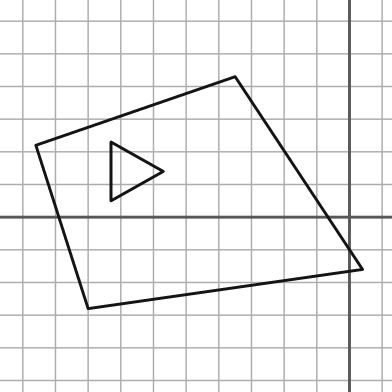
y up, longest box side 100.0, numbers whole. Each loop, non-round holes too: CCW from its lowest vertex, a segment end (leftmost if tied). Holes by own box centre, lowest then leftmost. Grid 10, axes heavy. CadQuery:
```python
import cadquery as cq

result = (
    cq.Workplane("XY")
    .moveTo(-80.0, -28.0)
    .lineTo(4.0, -16.0)
    .lineTo(-35.0, 43.0)
    .lineTo(-96.0, 22.0)
    .close()
    .moveTo(-73.0, 5.0)
    .lineTo(-57.0, 14.0)
    .lineTo(-73.0, 23.0)
    .close()
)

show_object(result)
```